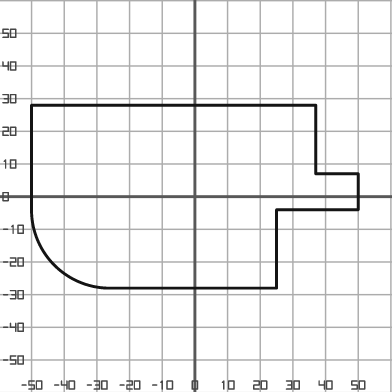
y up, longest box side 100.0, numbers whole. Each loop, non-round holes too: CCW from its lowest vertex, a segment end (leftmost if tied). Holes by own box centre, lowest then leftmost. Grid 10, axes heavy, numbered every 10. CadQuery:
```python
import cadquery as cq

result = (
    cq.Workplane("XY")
    .moveTo(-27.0, -28.0)
    .lineTo(25.0, -28.0)
    .lineTo(25.0, -4.0)
    .lineTo(50.0, -4.0)
    .lineTo(50.0, 7.0)
    .lineTo(37.0, 7.0)
    .lineTo(37.0, 28.0)
    .lineTo(-50.0, 28.0)
    .lineTo(-50.0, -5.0)
    .threePointArc((-43.0, -21.0), (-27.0, -28.0))
    .close()
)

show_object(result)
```